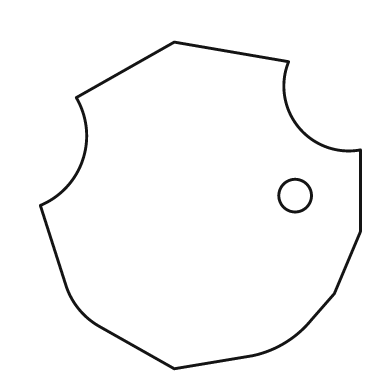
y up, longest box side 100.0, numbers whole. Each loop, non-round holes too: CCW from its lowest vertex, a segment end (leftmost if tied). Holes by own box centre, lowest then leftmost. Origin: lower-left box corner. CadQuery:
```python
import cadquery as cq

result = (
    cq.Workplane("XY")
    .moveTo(41.0, 0.0)
    .lineTo(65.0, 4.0)
    .threePointArc((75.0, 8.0), (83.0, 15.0))
    .lineTo(90.0, 23.0)
    .lineTo(98.0, 42.0)
    .lineTo(98.0, 67.0)
    .threePointArc((79.0, 74.0), (76.0, 94.0))
    .lineTo(41.0, 100.0)
    .lineTo(11.0, 83.0)
    .threePointArc((13.0, 64.0), (0.0, 50.0))
    .lineTo(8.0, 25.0)
    .threePointArc((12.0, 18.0), (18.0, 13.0))
    .close()
    .moveTo(78.0, 53.0)
    .circle(5.0)
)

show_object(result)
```